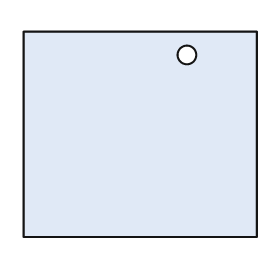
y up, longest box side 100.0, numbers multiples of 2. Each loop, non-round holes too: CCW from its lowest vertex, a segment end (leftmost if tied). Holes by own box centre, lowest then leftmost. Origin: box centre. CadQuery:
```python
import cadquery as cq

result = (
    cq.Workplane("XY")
    .moveTo(-50.0, -44.0)
    .lineTo(50.0, -44.0)
    .lineTo(50.0, 44.0)
    .lineTo(-50.0, 44.0)
    .close()
    .moveTo(20.0, 34.0)
    .circle(4.0)
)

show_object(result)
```